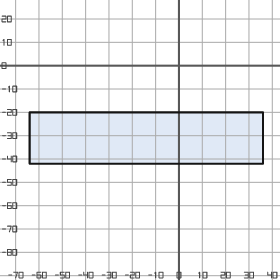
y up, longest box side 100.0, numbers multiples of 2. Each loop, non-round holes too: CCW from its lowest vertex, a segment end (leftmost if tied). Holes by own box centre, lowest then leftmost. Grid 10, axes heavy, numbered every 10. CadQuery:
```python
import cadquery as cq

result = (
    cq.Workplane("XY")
    .moveTo(-64.0, -42.0)
    .lineTo(36.0, -42.0)
    .lineTo(36.0, -20.0)
    .lineTo(-64.0, -20.0)
    .close()
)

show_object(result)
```